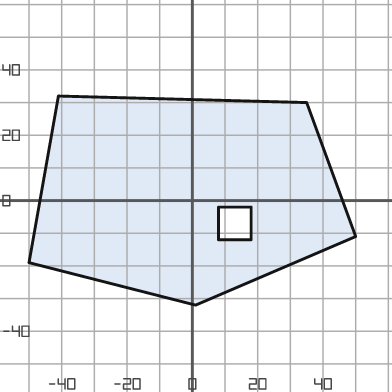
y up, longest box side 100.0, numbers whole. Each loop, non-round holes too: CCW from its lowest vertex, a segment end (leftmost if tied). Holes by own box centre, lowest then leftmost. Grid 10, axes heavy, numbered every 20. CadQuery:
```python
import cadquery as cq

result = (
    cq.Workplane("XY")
    .moveTo(1.0, -32.0)
    .lineTo(50.0, -11.0)
    .lineTo(35.0, 30.0)
    .lineTo(-41.0, 32.0)
    .lineTo(-50.0, -19.0)
    .close()
    .moveTo(8.0, -12.0)
    .lineTo(18.0, -12.0)
    .lineTo(18.0, -2.0)
    .lineTo(8.0, -2.0)
    .close()
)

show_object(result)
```